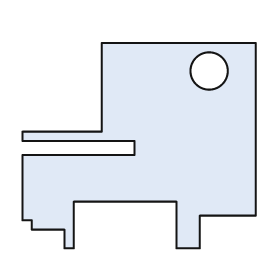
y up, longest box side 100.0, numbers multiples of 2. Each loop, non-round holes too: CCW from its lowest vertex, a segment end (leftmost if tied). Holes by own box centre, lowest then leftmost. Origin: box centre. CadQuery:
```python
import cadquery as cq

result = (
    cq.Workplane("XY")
    .moveTo(-32.0, -44.0)
    .lineTo(-28.0, -44.0)
    .lineTo(-28.0, -24.0)
    .lineTo(16.0, -24.0)
    .lineTo(16.0, -44.0)
    .lineTo(26.0, -44.0)
    .lineTo(26.0, -30.0)
    .lineTo(50.0, -30.0)
    .lineTo(50.0, 44.0)
    .lineTo(-16.0, 44.0)
    .lineTo(-16.0, 6.0)
    .lineTo(-50.0, 6.0)
    .lineTo(-50.0, 2.0)
    .lineTo(-2.0, 2.0)
    .lineTo(-2.0, -4.0)
    .lineTo(-50.0, -4.0)
    .lineTo(-50.0, -32.0)
    .lineTo(-46.0, -32.0)
    .lineTo(-46.0, -36.0)
    .lineTo(-32.0, -36.0)
    .close()
    .moveTo(30.0, 32.0)
    .circle(8.0)
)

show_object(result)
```